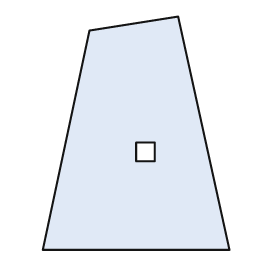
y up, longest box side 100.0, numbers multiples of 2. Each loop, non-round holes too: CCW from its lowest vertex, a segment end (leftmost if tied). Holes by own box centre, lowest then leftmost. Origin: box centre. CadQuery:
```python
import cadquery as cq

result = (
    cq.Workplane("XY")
    .moveTo(-40.0, -50.0)
    .lineTo(40.0, -50.0)
    .lineTo(18.0, 50.0)
    .lineTo(-20.0, 44.0)
    .close()
    .moveTo(0.0, -12.0)
    .lineTo(8.0, -12.0)
    .lineTo(8.0, -4.0)
    .lineTo(0.0, -4.0)
    .close()
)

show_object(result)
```